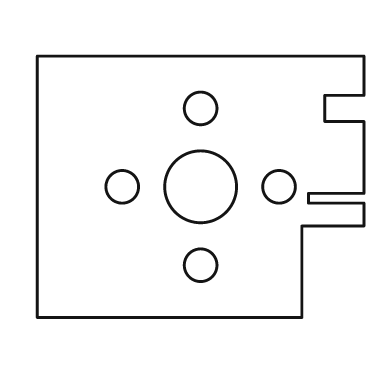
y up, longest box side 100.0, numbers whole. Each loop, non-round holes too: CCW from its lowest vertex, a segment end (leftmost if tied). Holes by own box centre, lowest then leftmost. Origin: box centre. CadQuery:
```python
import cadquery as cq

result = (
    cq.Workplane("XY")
    .moveTo(-50.0, -40.0)
    .lineTo(31.0, -40.0)
    .lineTo(31.0, -12.0)
    .lineTo(50.0, -12.0)
    .lineTo(50.0, -5.0)
    .lineTo(33.0, -5.0)
    .lineTo(33.0, -2.0)
    .lineTo(50.0, -2.0)
    .lineTo(50.0, 20.0)
    .lineTo(38.0, 20.0)
    .lineTo(38.0, 28.0)
    .lineTo(50.0, 28.0)
    .lineTo(50.0, 40.0)
    .lineTo(-50.0, 40.0)
    .close()
    .moveTo(0.0, -24.0)
    .circle(5.0)
    .moveTo(-24.0, 0.0)
    .circle(5.0)
    .moveTo(0.0, 0.0)
    .circle(11.0)
    .moveTo(24.0, 0.0)
    .circle(5.0)
    .moveTo(0.0, 24.0)
    .circle(5.0)
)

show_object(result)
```